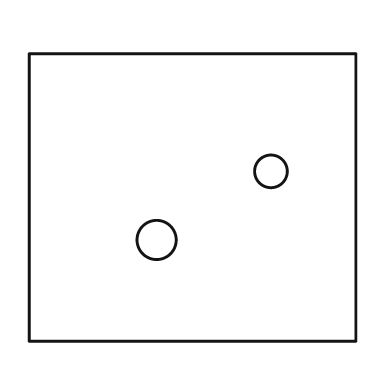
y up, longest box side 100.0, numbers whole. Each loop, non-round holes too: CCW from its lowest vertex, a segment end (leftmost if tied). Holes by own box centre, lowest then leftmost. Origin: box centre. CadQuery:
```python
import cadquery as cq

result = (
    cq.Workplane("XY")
    .moveTo(-50.0, -44.0)
    .lineTo(50.0, -44.0)
    .lineTo(50.0, 44.0)
    .lineTo(-50.0, 44.0)
    .close()
    .moveTo(-11.0, -13.0)
    .circle(6.0)
    .moveTo(24.0, 8.0)
    .circle(5.0)
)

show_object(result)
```